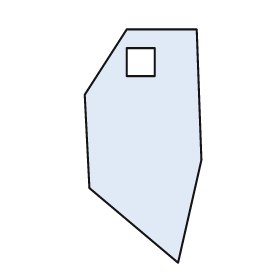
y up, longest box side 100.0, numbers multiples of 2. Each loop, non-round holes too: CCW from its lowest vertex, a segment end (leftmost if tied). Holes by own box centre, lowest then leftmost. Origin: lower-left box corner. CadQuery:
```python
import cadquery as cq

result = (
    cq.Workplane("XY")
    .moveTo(40.0, 0.0)
    .lineTo(50.0, 44.0)
    .lineTo(48.0, 100.0)
    .lineTo(18.0, 100.0)
    .lineTo(0.0, 72.0)
    .lineTo(2.0, 32.0)
    .close()
    .moveTo(18.0, 80.0)
    .lineTo(30.0, 80.0)
    .lineTo(30.0, 92.0)
    .lineTo(18.0, 92.0)
    .close()
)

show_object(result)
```